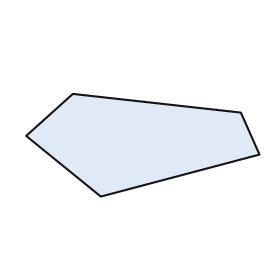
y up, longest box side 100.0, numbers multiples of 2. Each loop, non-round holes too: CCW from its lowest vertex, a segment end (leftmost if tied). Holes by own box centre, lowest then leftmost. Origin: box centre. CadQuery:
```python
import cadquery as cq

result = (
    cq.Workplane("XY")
    .moveTo(-18.0, -22.0)
    .lineTo(50.0, -4.0)
    .lineTo(42.0, 14.0)
    .lineTo(-30.0, 22.0)
    .lineTo(-50.0, 4.0)
    .close()
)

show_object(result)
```